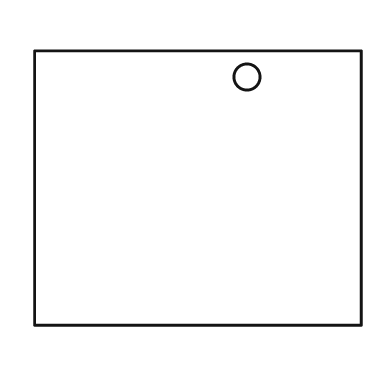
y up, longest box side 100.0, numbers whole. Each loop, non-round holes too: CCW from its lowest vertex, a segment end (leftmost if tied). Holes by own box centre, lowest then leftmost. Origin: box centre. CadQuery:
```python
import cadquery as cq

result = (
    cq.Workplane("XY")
    .moveTo(-50.0, -42.0)
    .lineTo(50.0, -42.0)
    .lineTo(50.0, 42.0)
    .lineTo(-50.0, 42.0)
    .close()
    .moveTo(15.0, 34.0)
    .circle(4.0)
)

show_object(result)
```